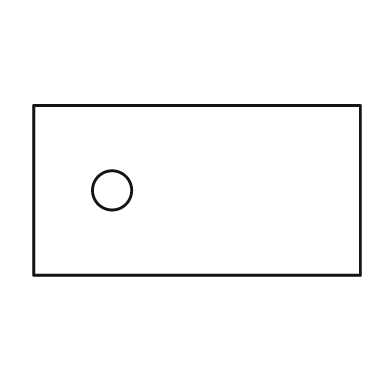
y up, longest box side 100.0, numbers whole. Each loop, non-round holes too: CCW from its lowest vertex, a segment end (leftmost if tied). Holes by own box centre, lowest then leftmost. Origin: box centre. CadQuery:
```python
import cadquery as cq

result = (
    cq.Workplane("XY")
    .moveTo(-50.0, -26.0)
    .lineTo(50.0, -26.0)
    .lineTo(50.0, 26.0)
    .lineTo(-50.0, 26.0)
    .close()
    .moveTo(-26.0, 0.0)
    .circle(6.0)
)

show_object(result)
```